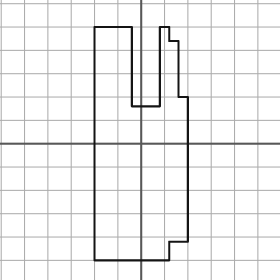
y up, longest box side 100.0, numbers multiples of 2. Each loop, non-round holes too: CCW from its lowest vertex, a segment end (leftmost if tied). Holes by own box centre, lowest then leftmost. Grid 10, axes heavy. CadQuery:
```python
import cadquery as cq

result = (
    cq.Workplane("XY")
    .moveTo(-20.0, -50.0)
    .lineTo(12.0, -50.0)
    .lineTo(12.0, -42.0)
    .lineTo(20.0, -42.0)
    .lineTo(20.0, 20.0)
    .lineTo(16.0, 20.0)
    .lineTo(16.0, 44.0)
    .lineTo(12.0, 44.0)
    .lineTo(12.0, 50.0)
    .lineTo(8.0, 50.0)
    .lineTo(8.0, 16.0)
    .lineTo(-4.0, 16.0)
    .lineTo(-4.0, 50.0)
    .lineTo(-20.0, 50.0)
    .close()
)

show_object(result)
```